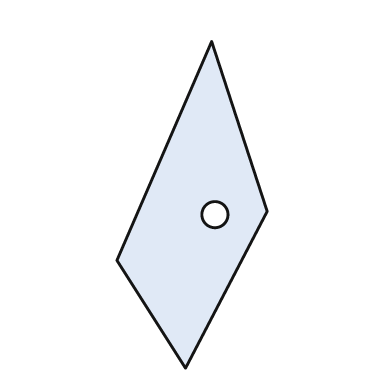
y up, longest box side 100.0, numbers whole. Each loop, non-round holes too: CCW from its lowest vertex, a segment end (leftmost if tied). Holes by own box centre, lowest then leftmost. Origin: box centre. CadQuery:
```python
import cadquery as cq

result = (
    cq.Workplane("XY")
    .moveTo(-2.0, -50.0)
    .lineTo(23.0, -2.0)
    .lineTo(6.0, 50.0)
    .lineTo(-23.0, -17.0)
    .close()
    .moveTo(7.0, -3.0)
    .circle(4.0)
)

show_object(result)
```